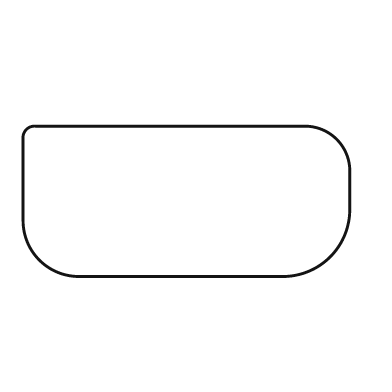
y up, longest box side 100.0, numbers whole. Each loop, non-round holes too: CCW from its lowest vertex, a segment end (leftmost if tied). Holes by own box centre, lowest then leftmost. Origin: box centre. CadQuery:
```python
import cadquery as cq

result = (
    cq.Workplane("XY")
    .moveTo(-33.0, -23.0)
    .lineTo(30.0, -23.0)
    .threePointArc((44.0, -17.0), (50.0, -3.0))
    .lineTo(50.0, 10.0)
    .threePointArc((46.0, 19.0), (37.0, 23.0))
    .lineTo(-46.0, 23.0)
    .threePointArc((-49.0, 22.0), (-50.0, 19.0))
    .lineTo(-50.0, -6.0)
    .threePointArc((-45.0, -18.0), (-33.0, -23.0))
    .close()
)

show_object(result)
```